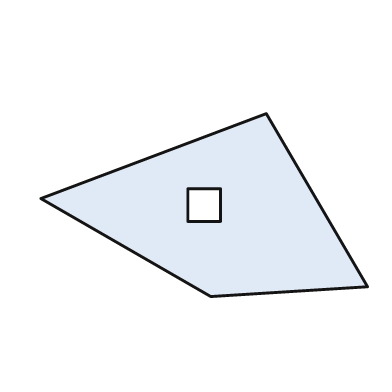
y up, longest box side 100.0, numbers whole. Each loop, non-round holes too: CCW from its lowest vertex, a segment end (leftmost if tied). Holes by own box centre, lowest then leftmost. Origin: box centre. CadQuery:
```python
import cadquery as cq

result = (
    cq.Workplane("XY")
    .moveTo(2.0, -28.0)
    .lineTo(50.0, -25.0)
    .lineTo(19.0, 28.0)
    .lineTo(-50.0, 2.0)
    .close()
    .moveTo(-5.0, -5.0)
    .lineTo(5.0, -5.0)
    .lineTo(5.0, 5.0)
    .lineTo(-5.0, 5.0)
    .close()
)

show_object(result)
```